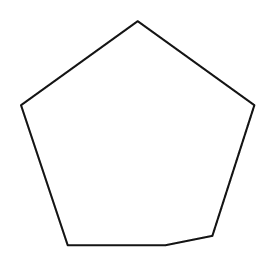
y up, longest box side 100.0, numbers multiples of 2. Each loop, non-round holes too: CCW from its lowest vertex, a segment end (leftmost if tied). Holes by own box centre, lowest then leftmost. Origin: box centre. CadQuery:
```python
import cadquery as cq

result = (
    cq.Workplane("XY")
    .moveTo(-30.0, -48.0)
    .lineTo(12.0, -48.0)
    .lineTo(32.0, -44.0)
    .lineTo(50.0, 12.0)
    .lineTo(0.0, 48.0)
    .lineTo(-50.0, 12.0)
    .close()
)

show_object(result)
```